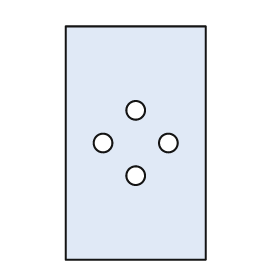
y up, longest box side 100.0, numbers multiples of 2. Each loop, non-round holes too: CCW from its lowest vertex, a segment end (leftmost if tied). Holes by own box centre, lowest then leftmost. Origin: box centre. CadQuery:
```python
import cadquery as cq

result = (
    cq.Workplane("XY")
    .moveTo(-30.0, -50.0)
    .lineTo(30.0, -50.0)
    .lineTo(30.0, 50.0)
    .lineTo(-30.0, 50.0)
    .close()
    .moveTo(0.0, -14.0)
    .circle(4.0)
    .moveTo(-14.0, 0.0)
    .circle(4.0)
    .moveTo(14.0, 0.0)
    .circle(4.0)
    .moveTo(0.0, 14.0)
    .circle(4.0)
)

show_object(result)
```